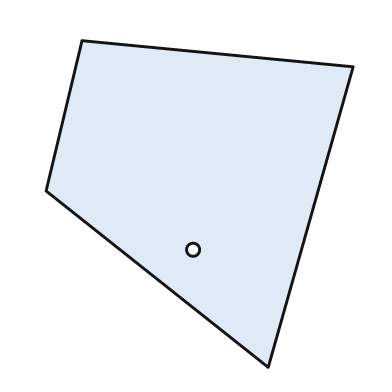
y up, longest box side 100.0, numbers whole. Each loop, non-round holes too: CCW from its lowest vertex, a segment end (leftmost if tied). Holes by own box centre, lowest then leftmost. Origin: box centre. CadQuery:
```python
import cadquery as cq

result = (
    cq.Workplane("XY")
    .moveTo(21.0, -50.0)
    .lineTo(47.0, 42.0)
    .lineTo(-36.0, 50.0)
    .lineTo(-47.0, 4.0)
    .close()
    .moveTo(-2.0, -14.0)
    .circle(2.0)
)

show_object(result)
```